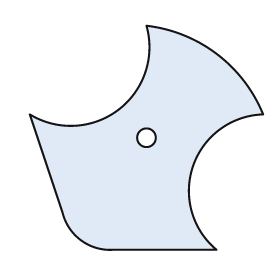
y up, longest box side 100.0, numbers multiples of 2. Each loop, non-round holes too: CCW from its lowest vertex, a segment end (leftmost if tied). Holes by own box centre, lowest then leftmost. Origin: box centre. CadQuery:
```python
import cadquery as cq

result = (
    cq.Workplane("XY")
    .moveTo(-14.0, -48.0)
    .lineTo(30.0, -48.0)
    .threePointArc((20.0, -12.0), (50.0, 10.0))
    .threePointArc((30.0, 36.0), (0.0, 48.0))
    .threePointArc((-12.0, 12.0), (-50.0, 10.0))
    .lineTo(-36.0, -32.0)
    .threePointArc((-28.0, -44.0), (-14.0, -48.0))
    .close()
    .moveTo(0.0, 0.0)
    .circle(4.0)
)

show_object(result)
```